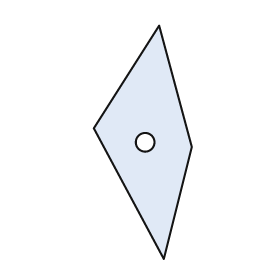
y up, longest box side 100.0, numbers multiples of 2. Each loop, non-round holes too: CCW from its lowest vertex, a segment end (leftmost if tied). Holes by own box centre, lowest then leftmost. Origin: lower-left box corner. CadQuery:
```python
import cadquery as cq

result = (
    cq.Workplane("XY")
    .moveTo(30.0, 0.0)
    .lineTo(42.0, 48.0)
    .lineTo(28.0, 100.0)
    .lineTo(0.0, 56.0)
    .close()
    .moveTo(22.0, 50.0)
    .circle(4.0)
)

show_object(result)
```